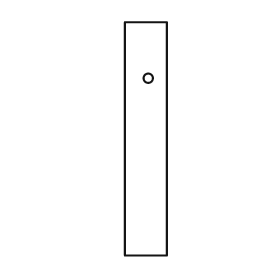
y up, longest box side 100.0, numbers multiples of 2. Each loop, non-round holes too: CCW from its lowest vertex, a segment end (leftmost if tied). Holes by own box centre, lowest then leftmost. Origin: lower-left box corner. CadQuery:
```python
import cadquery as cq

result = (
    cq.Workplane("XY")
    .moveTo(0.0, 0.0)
    .lineTo(18.0, 0.0)
    .lineTo(18.0, 100.0)
    .lineTo(0.0, 100.0)
    .close()
    .moveTo(10.0, 76.0)
    .circle(2.0)
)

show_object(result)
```